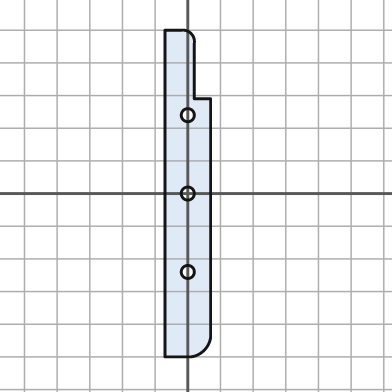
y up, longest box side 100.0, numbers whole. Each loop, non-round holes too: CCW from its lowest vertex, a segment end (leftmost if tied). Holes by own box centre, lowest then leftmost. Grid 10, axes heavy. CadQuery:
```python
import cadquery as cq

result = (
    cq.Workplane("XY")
    .moveTo(-7.0, -50.0)
    .lineTo(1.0, -50.0)
    .threePointArc((5.0, -48.0), (7.0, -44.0))
    .lineTo(7.0, 29.0)
    .lineTo(2.0, 29.0)
    .lineTo(2.0, 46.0)
    .threePointArc((1.0, 49.0), (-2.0, 50.0))
    .lineTo(-7.0, 50.0)
    .close()
    .moveTo(0.0, -24.0)
    .circle(2.0)
    .moveTo(0.0, 0.0)
    .circle(2.0)
    .moveTo(0.0, 24.0)
    .circle(2.0)
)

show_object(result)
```